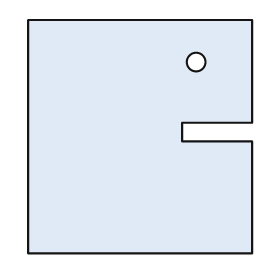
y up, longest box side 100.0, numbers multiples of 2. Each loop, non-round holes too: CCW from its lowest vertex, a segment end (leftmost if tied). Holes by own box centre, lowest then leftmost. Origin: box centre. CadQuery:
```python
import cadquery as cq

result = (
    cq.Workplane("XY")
    .moveTo(-48.0, -50.0)
    .lineTo(48.0, -50.0)
    .lineTo(48.0, -2.0)
    .lineTo(18.0, -2.0)
    .lineTo(18.0, 6.0)
    .lineTo(48.0, 6.0)
    .lineTo(48.0, 50.0)
    .lineTo(-48.0, 50.0)
    .close()
    .moveTo(24.0, 32.0)
    .circle(4.0)
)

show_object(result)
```